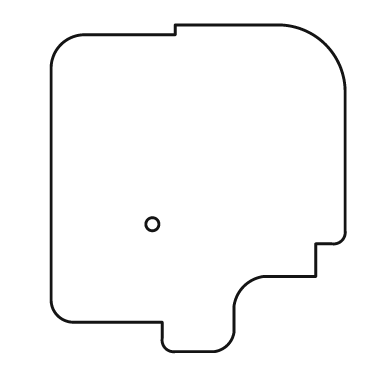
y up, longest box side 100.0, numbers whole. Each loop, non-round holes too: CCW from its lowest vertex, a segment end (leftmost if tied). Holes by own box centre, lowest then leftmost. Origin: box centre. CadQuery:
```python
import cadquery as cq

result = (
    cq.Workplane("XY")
    .moveTo(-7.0, -50.0)
    .lineTo(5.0, -50.0)
    .threePointArc((9.0, -48.0), (11.0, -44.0))
    .lineTo(11.0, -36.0)
    .threePointArc((14.0, -30.0), (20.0, -27.0))
    .lineTo(36.0, -27.0)
    .lineTo(36.0, -17.0)
    .lineTo(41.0, -17.0)
    .threePointArc((44.0, -16.0), (45.0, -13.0))
    .lineTo(45.0, 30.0)
    .threePointArc((39.0, 44.0), (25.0, 50.0))
    .lineTo(-7.0, 50.0)
    .lineTo(-7.0, 47.0)
    .lineTo(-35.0, 47.0)
    .threePointArc((-42.0, 44.0), (-45.0, 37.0))
    .lineTo(-45.0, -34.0)
    .threePointArc((-43.0, -39.0), (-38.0, -41.0))
    .lineTo(-11.0, -41.0)
    .lineTo(-11.0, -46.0)
    .threePointArc((-10.0, -49.0), (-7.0, -50.0))
    .close()
    .moveTo(-14.0, -11.0)
    .circle(2.0)
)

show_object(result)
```